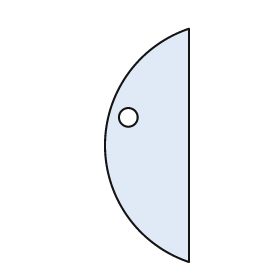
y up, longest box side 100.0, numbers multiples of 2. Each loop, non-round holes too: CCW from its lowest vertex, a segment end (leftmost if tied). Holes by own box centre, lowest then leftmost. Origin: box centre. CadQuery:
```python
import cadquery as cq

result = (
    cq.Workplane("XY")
    .moveTo(18.0, -50.0)
    .lineTo(18.0, 50.0)
    .threePointArc((-18.0, 0.0), (18.0, -50.0))
    .close()
    .moveTo(-8.0, 12.0)
    .circle(4.0)
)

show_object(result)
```